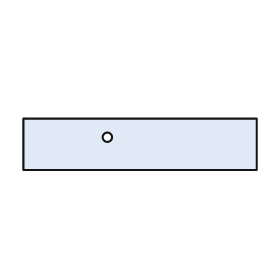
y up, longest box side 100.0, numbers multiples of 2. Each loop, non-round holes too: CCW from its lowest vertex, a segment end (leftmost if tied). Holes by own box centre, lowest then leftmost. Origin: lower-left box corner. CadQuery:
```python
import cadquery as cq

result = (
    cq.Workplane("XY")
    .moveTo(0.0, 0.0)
    .lineTo(100.0, 0.0)
    .lineTo(100.0, 22.0)
    .lineTo(0.0, 22.0)
    .close()
    .moveTo(36.0, 14.0)
    .circle(2.0)
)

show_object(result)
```